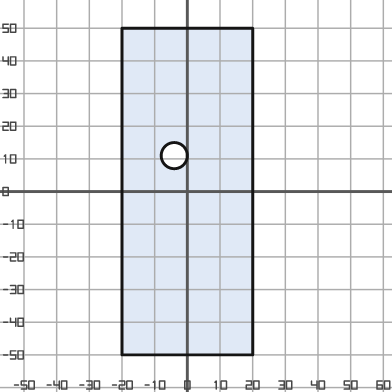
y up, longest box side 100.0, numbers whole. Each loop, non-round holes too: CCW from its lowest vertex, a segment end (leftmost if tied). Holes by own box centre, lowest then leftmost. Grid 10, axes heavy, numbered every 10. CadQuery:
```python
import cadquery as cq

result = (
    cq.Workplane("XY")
    .moveTo(-20.0, -50.0)
    .lineTo(20.0, -50.0)
    .lineTo(20.0, 50.0)
    .lineTo(-20.0, 50.0)
    .close()
    .moveTo(-4.0, 11.0)
    .circle(4.0)
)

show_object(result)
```